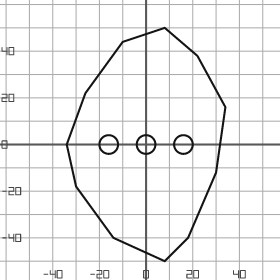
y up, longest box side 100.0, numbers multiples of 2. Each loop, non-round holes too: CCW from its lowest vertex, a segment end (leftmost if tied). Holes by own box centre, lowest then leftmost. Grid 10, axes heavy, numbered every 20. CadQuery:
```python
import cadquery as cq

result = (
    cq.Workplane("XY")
    .moveTo(8.0, -50.0)
    .lineTo(18.0, -40.0)
    .lineTo(30.0, -12.0)
    .lineTo(34.0, 16.0)
    .lineTo(22.0, 38.0)
    .lineTo(8.0, 50.0)
    .lineTo(-10.0, 44.0)
    .lineTo(-26.0, 22.0)
    .lineTo(-34.0, 0.0)
    .lineTo(-30.0, -18.0)
    .lineTo(-14.0, -40.0)
    .close()
    .moveTo(-16.0, 0.0)
    .circle(4.0)
    .moveTo(0.0, 0.0)
    .circle(4.0)
    .moveTo(16.0, 0.0)
    .circle(4.0)
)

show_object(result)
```